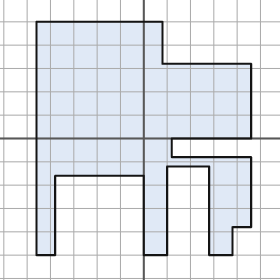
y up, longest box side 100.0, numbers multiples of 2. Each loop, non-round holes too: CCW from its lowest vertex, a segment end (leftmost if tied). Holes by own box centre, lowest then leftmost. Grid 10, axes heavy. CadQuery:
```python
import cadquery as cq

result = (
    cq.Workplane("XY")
    .moveTo(-46.0, -50.0)
    .lineTo(-38.0, -50.0)
    .lineTo(-38.0, -16.0)
    .lineTo(0.0, -16.0)
    .lineTo(0.0, -50.0)
    .lineTo(10.0, -50.0)
    .lineTo(10.0, -12.0)
    .lineTo(28.0, -12.0)
    .lineTo(28.0, -50.0)
    .lineTo(38.0, -50.0)
    .lineTo(38.0, -38.0)
    .lineTo(46.0, -38.0)
    .lineTo(46.0, -8.0)
    .lineTo(12.0, -8.0)
    .lineTo(12.0, 0.0)
    .lineTo(46.0, 0.0)
    .lineTo(46.0, 32.0)
    .lineTo(8.0, 32.0)
    .lineTo(8.0, 50.0)
    .lineTo(-46.0, 50.0)
    .close()
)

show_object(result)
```